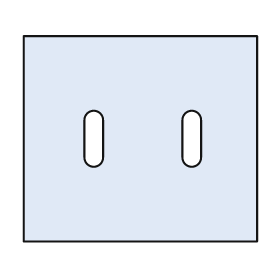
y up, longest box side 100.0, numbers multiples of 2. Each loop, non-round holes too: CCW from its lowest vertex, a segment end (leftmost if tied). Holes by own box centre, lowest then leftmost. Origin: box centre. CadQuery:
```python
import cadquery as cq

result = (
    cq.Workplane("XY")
    .moveTo(-50.0, -44.0)
    .lineTo(50.0, -44.0)
    .lineTo(50.0, 44.0)
    .lineTo(-50.0, 44.0)
    .close()
    .moveTo(-24.0, -8.0)
    .threePointArc((-20.0, -12.0), (-16.0, -8.0))
    .lineTo(-16.0, 8.0)
    .threePointArc((-20.0, 12.0), (-24.0, 8.0))
    .close()
    .moveTo(18.0, -8.0)
    .threePointArc((22.0, -12.0), (26.0, -8.0))
    .lineTo(26.0, 8.0)
    .threePointArc((22.0, 12.0), (18.0, 8.0))
    .close()
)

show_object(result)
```